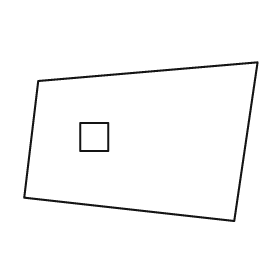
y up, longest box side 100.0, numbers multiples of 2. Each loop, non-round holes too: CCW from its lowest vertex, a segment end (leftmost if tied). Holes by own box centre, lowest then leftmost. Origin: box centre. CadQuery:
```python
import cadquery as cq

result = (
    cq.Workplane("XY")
    .moveTo(40.0, -34.0)
    .lineTo(50.0, 34.0)
    .lineTo(-44.0, 26.0)
    .lineTo(-50.0, -24.0)
    .close()
    .moveTo(-26.0, -4.0)
    .lineTo(-14.0, -4.0)
    .lineTo(-14.0, 8.0)
    .lineTo(-26.0, 8.0)
    .close()
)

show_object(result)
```